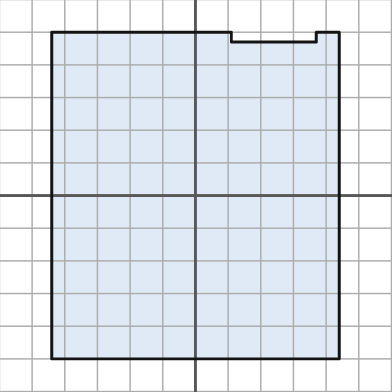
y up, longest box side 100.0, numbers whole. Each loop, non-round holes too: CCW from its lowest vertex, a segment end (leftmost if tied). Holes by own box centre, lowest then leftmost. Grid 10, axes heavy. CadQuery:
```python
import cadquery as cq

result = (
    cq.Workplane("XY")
    .moveTo(-44.0, -50.0)
    .lineTo(44.0, -50.0)
    .lineTo(44.0, 50.0)
    .lineTo(37.0, 50.0)
    .lineTo(37.0, 47.0)
    .lineTo(11.0, 47.0)
    .lineTo(11.0, 50.0)
    .lineTo(-44.0, 50.0)
    .close()
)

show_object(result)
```